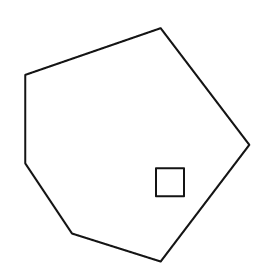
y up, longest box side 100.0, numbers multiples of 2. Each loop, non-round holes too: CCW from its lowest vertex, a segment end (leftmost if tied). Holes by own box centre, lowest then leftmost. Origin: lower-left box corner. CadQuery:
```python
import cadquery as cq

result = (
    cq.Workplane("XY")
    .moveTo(58.0, 0.0)
    .lineTo(96.0, 50.0)
    .lineTo(58.0, 100.0)
    .lineTo(0.0, 80.0)
    .lineTo(0.0, 42.0)
    .lineTo(20.0, 12.0)
    .close()
    .moveTo(56.0, 28.0)
    .lineTo(68.0, 28.0)
    .lineTo(68.0, 40.0)
    .lineTo(56.0, 40.0)
    .close()
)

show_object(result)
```